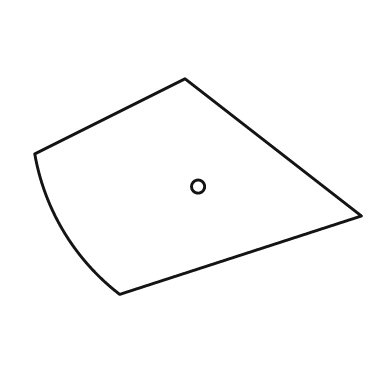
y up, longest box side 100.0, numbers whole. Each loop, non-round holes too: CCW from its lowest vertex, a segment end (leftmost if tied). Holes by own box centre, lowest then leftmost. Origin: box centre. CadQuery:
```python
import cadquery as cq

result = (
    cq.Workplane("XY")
    .moveTo(-24.0, -33.0)
    .lineTo(50.0, -9.0)
    .lineTo(-4.0, 33.0)
    .lineTo(-50.0, 10.0)
    .threePointArc((-41.0, -14.0), (-24.0, -33.0))
    .close()
    .moveTo(0.0, 0.0)
    .circle(2.0)
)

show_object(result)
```